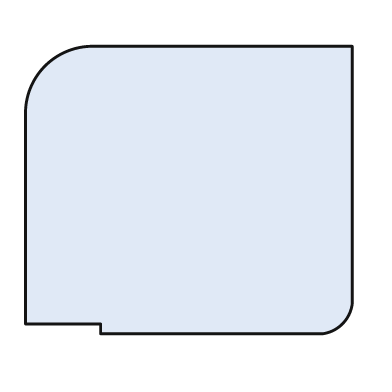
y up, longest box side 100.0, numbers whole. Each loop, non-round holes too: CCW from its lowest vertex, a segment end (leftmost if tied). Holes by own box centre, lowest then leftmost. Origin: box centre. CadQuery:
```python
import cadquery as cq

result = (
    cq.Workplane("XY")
    .moveTo(-27.0, -44.0)
    .lineTo(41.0, -44.0)
    .threePointArc((47.0, -41.0), (50.0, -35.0))
    .lineTo(50.0, 44.0)
    .lineTo(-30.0, 44.0)
    .threePointArc((-44.0, 38.0), (-50.0, 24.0))
    .lineTo(-50.0, -41.0)
    .lineTo(-27.0, -41.0)
    .close()
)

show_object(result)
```